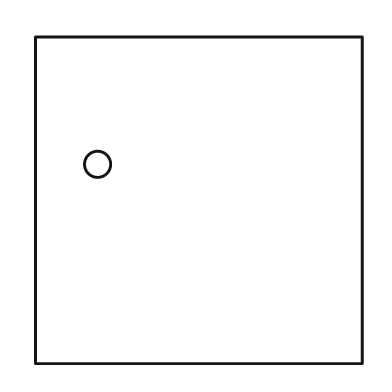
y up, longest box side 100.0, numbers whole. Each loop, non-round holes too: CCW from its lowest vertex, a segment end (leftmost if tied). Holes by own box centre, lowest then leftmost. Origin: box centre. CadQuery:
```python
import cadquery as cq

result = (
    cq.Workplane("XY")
    .moveTo(-50.0, -50.0)
    .lineTo(50.0, -50.0)
    .lineTo(50.0, 50.0)
    .lineTo(-50.0, 50.0)
    .close()
    .moveTo(-31.0, 11.0)
    .circle(4.0)
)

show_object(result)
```